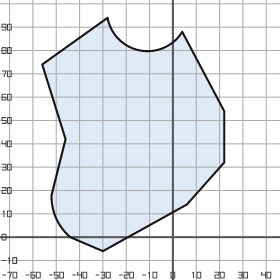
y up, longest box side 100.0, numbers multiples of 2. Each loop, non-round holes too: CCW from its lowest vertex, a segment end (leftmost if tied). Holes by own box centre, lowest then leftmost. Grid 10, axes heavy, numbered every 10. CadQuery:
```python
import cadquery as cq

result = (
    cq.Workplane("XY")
    .moveTo(-30.0, -6.0)
    .lineTo(6.0, 14.0)
    .lineTo(22.0, 32.0)
    .lineTo(22.0, 54.0)
    .lineTo(4.0, 88.0)
    .threePointArc((-14.0, 80.0), (-28.0, 94.0))
    .lineTo(-56.0, 74.0)
    .lineTo(-46.0, 42.0)
    .lineTo(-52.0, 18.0)
    .threePointArc((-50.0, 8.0), (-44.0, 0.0))
    .close()
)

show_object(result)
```